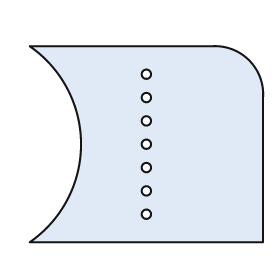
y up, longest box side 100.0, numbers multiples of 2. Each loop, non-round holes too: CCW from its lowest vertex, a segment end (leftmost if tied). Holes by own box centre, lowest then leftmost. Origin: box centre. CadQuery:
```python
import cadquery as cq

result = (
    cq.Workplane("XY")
    .moveTo(-50.0, -42.0)
    .lineTo(50.0, -42.0)
    .lineTo(50.0, 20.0)
    .threePointArc((44.0, 36.0), (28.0, 42.0))
    .lineTo(-50.0, 42.0)
    .threePointArc((-28.0, 0.0), (-50.0, -42.0))
    .close()
    .moveTo(0.0, -30.0)
    .circle(2.0)
    .moveTo(0.0, -20.0)
    .circle(2.0)
    .moveTo(0.0, -10.0)
    .circle(2.0)
    .moveTo(0.0, 0.0)
    .circle(2.0)
    .moveTo(0.0, 10.0)
    .circle(2.0)
    .moveTo(0.0, 20.0)
    .circle(2.0)
    .moveTo(0.0, 30.0)
    .circle(2.0)
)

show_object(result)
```